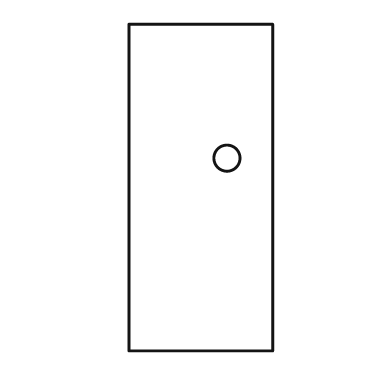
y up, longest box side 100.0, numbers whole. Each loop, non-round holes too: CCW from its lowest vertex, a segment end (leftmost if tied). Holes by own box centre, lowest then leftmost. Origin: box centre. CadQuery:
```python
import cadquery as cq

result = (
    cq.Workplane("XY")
    .moveTo(-22.0, -50.0)
    .lineTo(22.0, -50.0)
    .lineTo(22.0, 50.0)
    .lineTo(-22.0, 50.0)
    .close()
    .moveTo(8.0, 9.0)
    .circle(4.0)
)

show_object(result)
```